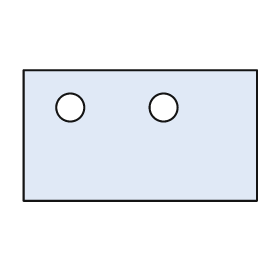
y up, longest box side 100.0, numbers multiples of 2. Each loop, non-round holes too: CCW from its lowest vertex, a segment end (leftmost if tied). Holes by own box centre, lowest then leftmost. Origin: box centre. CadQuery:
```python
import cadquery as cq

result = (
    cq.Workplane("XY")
    .moveTo(-50.0, -28.0)
    .lineTo(50.0, -28.0)
    .lineTo(50.0, 28.0)
    .lineTo(-50.0, 28.0)
    .close()
    .moveTo(-30.0, 12.0)
    .circle(6.0)
    .moveTo(10.0, 12.0)
    .circle(6.0)
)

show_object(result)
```